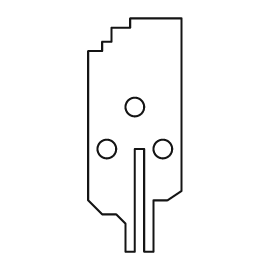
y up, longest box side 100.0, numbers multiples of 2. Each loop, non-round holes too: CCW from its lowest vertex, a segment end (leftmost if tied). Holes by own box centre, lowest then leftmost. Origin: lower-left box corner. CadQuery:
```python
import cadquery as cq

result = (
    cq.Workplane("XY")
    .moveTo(16.0, 0.0)
    .lineTo(20.0, 0.0)
    .lineTo(20.0, 44.0)
    .lineTo(24.0, 44.0)
    .lineTo(24.0, 0.0)
    .lineTo(28.0, 0.0)
    .lineTo(28.0, 22.0)
    .lineTo(34.0, 22.0)
    .lineTo(40.0, 26.0)
    .lineTo(40.0, 100.0)
    .lineTo(18.0, 100.0)
    .lineTo(18.0, 96.0)
    .lineTo(10.0, 96.0)
    .lineTo(10.0, 90.0)
    .lineTo(6.0, 90.0)
    .lineTo(6.0, 86.0)
    .lineTo(0.0, 86.0)
    .lineTo(0.0, 22.0)
    .lineTo(6.0, 16.0)
    .lineTo(12.0, 16.0)
    .lineTo(16.0, 12.0)
    .close()
    .moveTo(8.0, 44.0)
    .circle(4.0)
    .moveTo(32.0, 44.0)
    .circle(4.0)
    .moveTo(20.0, 62.0)
    .circle(4.0)
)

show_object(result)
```